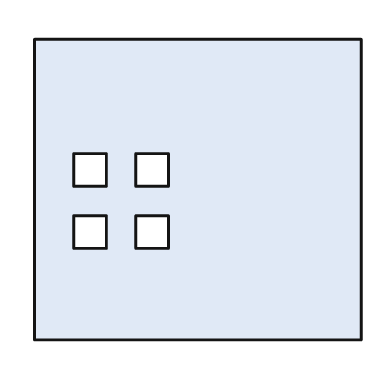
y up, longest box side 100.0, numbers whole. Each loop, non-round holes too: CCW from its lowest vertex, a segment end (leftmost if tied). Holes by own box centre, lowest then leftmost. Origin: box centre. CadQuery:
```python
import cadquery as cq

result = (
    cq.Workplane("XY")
    .moveTo(-50.0, -46.0)
    .lineTo(50.0, -46.0)
    .lineTo(50.0, 46.0)
    .lineTo(-50.0, 46.0)
    .close()
    .moveTo(-38.0, -18.0)
    .lineTo(-28.0, -18.0)
    .lineTo(-28.0, -8.0)
    .lineTo(-38.0, -8.0)
    .close()
    .moveTo(-19.0, -18.0)
    .lineTo(-9.0, -18.0)
    .lineTo(-9.0, -8.0)
    .lineTo(-19.0, -8.0)
    .close()
    .moveTo(-38.0, 1.0)
    .lineTo(-28.0, 1.0)
    .lineTo(-28.0, 11.0)
    .lineTo(-38.0, 11.0)
    .close()
    .moveTo(-19.0, 1.0)
    .lineTo(-9.0, 1.0)
    .lineTo(-9.0, 11.0)
    .lineTo(-19.0, 11.0)
    .close()
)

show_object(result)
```